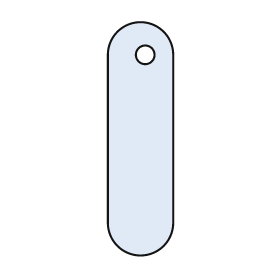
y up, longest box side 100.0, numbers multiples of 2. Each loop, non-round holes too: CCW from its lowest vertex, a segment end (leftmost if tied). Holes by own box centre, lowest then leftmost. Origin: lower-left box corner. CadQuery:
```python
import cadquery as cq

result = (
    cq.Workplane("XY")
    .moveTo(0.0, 14.0)
    .threePointArc((14.0, 0.0), (28.0, 14.0))
    .lineTo(28.0, 86.0)
    .threePointArc((14.0, 100.0), (0.0, 86.0))
    .close()
    .moveTo(16.0, 86.0)
    .circle(4.0)
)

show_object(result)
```